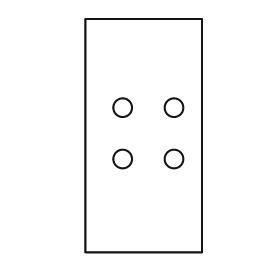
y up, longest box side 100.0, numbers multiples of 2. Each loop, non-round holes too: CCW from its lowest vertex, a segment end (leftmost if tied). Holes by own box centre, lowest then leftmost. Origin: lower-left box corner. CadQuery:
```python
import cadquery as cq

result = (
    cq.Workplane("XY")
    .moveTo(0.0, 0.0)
    .lineTo(50.0, 0.0)
    .lineTo(50.0, 100.0)
    .lineTo(0.0, 100.0)
    .close()
    .moveTo(16.0, 40.0)
    .circle(4.0)
    .moveTo(38.0, 40.0)
    .circle(4.0)
    .moveTo(16.0, 62.0)
    .circle(4.0)
    .moveTo(38.0, 62.0)
    .circle(4.0)
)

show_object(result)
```